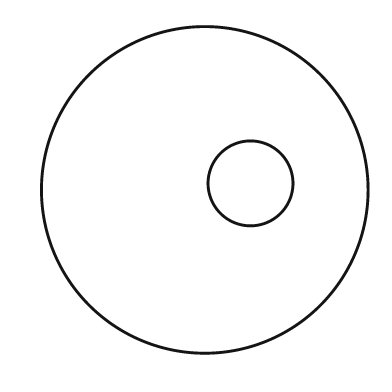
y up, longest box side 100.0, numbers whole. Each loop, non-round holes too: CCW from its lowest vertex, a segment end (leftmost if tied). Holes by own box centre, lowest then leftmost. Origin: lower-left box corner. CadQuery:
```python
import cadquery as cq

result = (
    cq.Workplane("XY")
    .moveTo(50.0, 50.0)
    .circle(50.0)
    .moveTo(64.0, 52.0)
    .circle(13.0)
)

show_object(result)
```